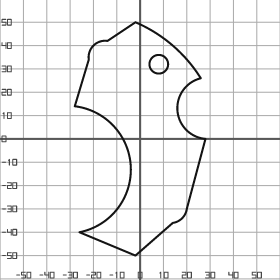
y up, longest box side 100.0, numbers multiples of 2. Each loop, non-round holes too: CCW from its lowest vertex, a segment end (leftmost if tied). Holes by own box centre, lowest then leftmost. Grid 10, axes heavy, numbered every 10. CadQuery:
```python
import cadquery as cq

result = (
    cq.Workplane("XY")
    .moveTo(-2.0, -50.0)
    .lineTo(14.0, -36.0)
    .threePointArc((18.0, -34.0), (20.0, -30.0))
    .lineTo(28.0, 0.0)
    .threePointArc((16.0, 12.0), (26.0, 26.0))
    .threePointArc((14.0, 40.0), (-2.0, 50.0))
    .lineTo(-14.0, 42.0)
    .threePointArc((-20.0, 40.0), (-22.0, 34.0))
    .lineTo(-28.0, 14.0)
    .threePointArc((-4.0, -12.0), (-26.0, -40.0))
    .close()
    .moveTo(8.0, 32.0)
    .circle(4.0)
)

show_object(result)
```